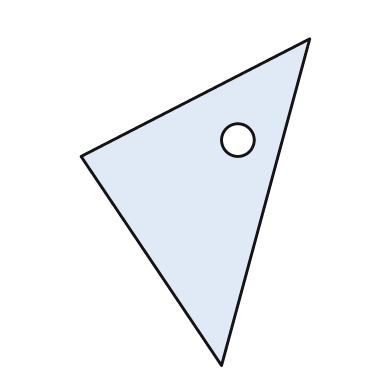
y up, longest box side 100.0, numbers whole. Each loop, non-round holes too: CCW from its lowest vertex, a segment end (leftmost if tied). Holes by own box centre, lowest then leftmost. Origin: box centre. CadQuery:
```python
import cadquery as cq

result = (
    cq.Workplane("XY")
    .moveTo(8.0, -50.0)
    .lineTo(35.0, 50.0)
    .lineTo(-35.0, 14.0)
    .close()
    .moveTo(13.0, 19.0)
    .circle(5.0)
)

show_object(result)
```